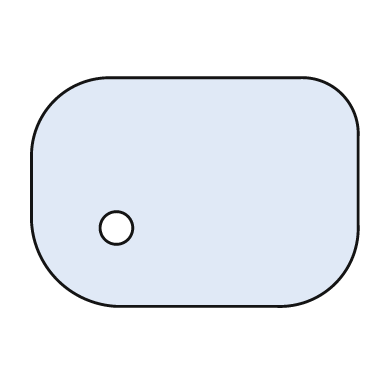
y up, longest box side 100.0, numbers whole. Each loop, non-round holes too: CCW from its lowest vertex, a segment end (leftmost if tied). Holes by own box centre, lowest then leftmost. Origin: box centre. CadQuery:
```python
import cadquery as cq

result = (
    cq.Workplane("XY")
    .moveTo(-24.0, -35.0)
    .lineTo(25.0, -35.0)
    .threePointArc((43.0, -28.0), (50.0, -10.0))
    .lineTo(50.0, 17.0)
    .threePointArc((45.0, 30.0), (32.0, 35.0))
    .lineTo(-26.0, 35.0)
    .threePointArc((-43.0, 28.0), (-50.0, 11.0))
    .lineTo(-50.0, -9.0)
    .threePointArc((-42.0, -27.0), (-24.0, -35.0))
    .close()
    .moveTo(-24.0, -11.0)
    .circle(5.0)
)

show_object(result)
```